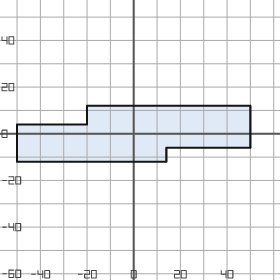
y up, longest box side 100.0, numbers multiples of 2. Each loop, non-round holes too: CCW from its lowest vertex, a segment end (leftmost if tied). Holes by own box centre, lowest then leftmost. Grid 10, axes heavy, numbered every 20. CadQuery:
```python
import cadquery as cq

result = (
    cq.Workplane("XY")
    .moveTo(-50.0, -12.0)
    .lineTo(14.0, -12.0)
    .lineTo(14.0, -6.0)
    .lineTo(50.0, -6.0)
    .lineTo(50.0, 12.0)
    .lineTo(-20.0, 12.0)
    .lineTo(-20.0, 4.0)
    .lineTo(-50.0, 4.0)
    .close()
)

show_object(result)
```